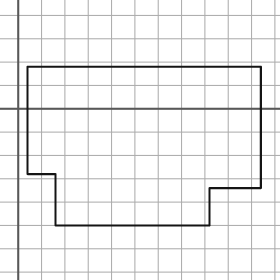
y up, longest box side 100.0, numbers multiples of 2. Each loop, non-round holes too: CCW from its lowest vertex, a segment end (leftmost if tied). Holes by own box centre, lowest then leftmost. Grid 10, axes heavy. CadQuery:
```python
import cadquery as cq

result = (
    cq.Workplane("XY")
    .moveTo(16.0, -50.0)
    .lineTo(82.0, -50.0)
    .lineTo(82.0, -34.0)
    .lineTo(104.0, -34.0)
    .lineTo(104.0, 18.0)
    .lineTo(4.0, 18.0)
    .lineTo(4.0, -28.0)
    .lineTo(16.0, -28.0)
    .close()
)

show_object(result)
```